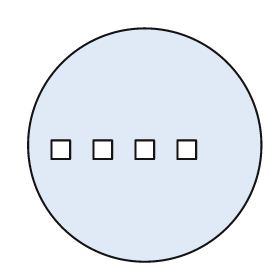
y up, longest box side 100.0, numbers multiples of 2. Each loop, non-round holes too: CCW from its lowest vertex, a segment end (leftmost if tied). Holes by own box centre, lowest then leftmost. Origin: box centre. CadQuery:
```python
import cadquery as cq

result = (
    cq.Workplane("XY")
    .moveTo(0.0, 0.0)
    .circle(50.0)
    .moveTo(-40.0, -6.0)
    .lineTo(-32.0, -6.0)
    .lineTo(-32.0, 2.0)
    .lineTo(-40.0, 2.0)
    .close()
    .moveTo(-22.0, -6.0)
    .lineTo(-14.0, -6.0)
    .lineTo(-14.0, 2.0)
    .lineTo(-22.0, 2.0)
    .close()
    .moveTo(-4.0, -6.0)
    .lineTo(4.0, -6.0)
    .lineTo(4.0, 2.0)
    .lineTo(-4.0, 2.0)
    .close()
    .moveTo(14.0, -6.0)
    .lineTo(22.0, -6.0)
    .lineTo(22.0, 2.0)
    .lineTo(14.0, 2.0)
    .close()
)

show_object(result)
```